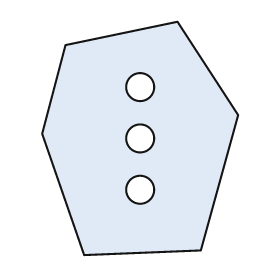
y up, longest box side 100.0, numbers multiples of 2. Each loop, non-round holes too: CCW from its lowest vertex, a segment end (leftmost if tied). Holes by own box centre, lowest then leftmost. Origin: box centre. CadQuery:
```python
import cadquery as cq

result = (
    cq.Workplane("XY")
    .moveTo(-24.0, -50.0)
    .lineTo(26.0, -48.0)
    .lineTo(42.0, 10.0)
    .lineTo(16.0, 50.0)
    .lineTo(-32.0, 40.0)
    .lineTo(-42.0, 2.0)
    .close()
    .moveTo(0.0, -22.0)
    .circle(6.0)
    .moveTo(0.0, 0.0)
    .circle(6.0)
    .moveTo(0.0, 22.0)
    .circle(6.0)
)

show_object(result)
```